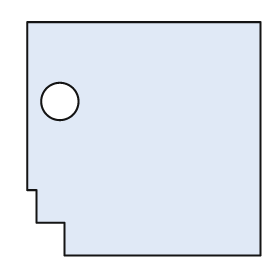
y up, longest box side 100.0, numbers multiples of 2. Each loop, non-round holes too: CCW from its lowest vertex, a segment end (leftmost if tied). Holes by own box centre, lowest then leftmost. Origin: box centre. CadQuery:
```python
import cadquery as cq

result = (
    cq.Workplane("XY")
    .moveTo(-34.0, -50.0)
    .lineTo(50.0, -50.0)
    .lineTo(50.0, 50.0)
    .lineTo(-50.0, 50.0)
    .lineTo(-50.0, -22.0)
    .lineTo(-46.0, -22.0)
    .lineTo(-46.0, -36.0)
    .lineTo(-34.0, -36.0)
    .close()
    .moveTo(-36.0, 16.0)
    .circle(8.0)
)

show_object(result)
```